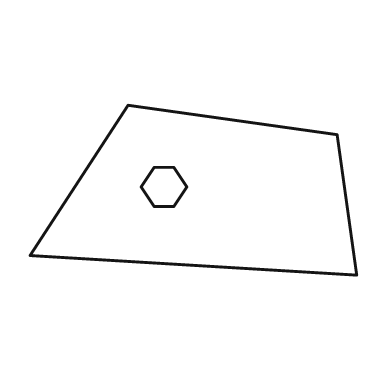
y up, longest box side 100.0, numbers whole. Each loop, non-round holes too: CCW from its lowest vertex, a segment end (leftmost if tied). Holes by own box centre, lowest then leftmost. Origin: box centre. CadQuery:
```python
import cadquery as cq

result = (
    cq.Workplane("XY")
    .moveTo(50.0, -26.0)
    .lineTo(44.0, 17.0)
    .lineTo(-20.0, 26.0)
    .lineTo(-50.0, -20.0)
    .close()
    .moveTo(-12.0, -5.0)
    .lineTo(-6.0, -5.0)
    .lineTo(-2.0, 1.0)
    .lineTo(-6.0, 7.0)
    .lineTo(-12.0, 7.0)
    .lineTo(-16.0, 1.0)
    .close()
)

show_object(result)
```